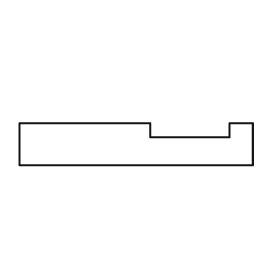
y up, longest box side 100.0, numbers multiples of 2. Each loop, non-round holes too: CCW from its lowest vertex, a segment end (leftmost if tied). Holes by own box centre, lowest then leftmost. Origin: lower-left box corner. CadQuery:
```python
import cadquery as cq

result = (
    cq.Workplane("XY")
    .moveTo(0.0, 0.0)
    .lineTo(100.0, 0.0)
    .lineTo(100.0, 18.0)
    .lineTo(90.0, 18.0)
    .lineTo(90.0, 12.0)
    .lineTo(56.0, 12.0)
    .lineTo(56.0, 18.0)
    .lineTo(0.0, 18.0)
    .close()
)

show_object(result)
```